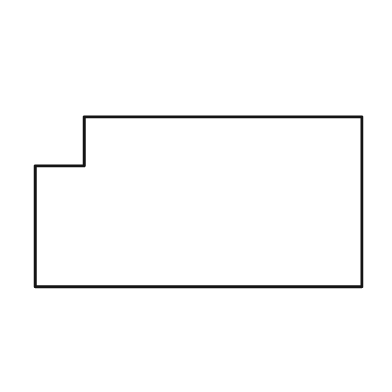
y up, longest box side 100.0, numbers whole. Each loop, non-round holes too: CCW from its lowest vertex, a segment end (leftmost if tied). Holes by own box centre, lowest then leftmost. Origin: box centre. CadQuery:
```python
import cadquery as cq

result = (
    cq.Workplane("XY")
    .moveTo(-50.0, -26.0)
    .lineTo(50.0, -26.0)
    .lineTo(50.0, 26.0)
    .lineTo(-35.0, 26.0)
    .lineTo(-35.0, 11.0)
    .lineTo(-50.0, 11.0)
    .close()
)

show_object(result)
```